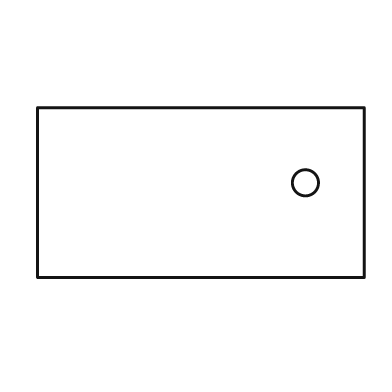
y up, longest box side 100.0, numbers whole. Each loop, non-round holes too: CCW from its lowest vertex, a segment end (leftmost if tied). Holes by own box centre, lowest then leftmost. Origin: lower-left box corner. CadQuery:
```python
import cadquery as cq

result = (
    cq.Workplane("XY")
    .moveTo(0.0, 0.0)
    .lineTo(100.0, 0.0)
    .lineTo(100.0, 52.0)
    .lineTo(0.0, 52.0)
    .close()
    .moveTo(82.0, 29.0)
    .circle(4.0)
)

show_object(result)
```